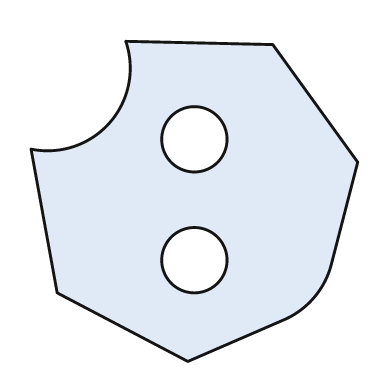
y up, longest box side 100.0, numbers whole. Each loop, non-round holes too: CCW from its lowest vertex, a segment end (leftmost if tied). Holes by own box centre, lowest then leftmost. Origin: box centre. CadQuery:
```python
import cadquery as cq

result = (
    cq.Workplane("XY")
    .moveTo(-2.0, -49.0)
    .lineTo(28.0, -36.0)
    .threePointArc((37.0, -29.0), (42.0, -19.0))
    .lineTo(50.0, 12.0)
    .lineTo(24.0, 48.0)
    .lineTo(-21.0, 49.0)
    .threePointArc((-26.0, 24.0), (-50.0, 16.0))
    .lineTo(-42.0, -28.0)
    .close()
    .moveTo(0.0, -18.0)
    .circle(10.0)
    .moveTo(0.0, 19.0)
    .circle(10.0)
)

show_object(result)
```